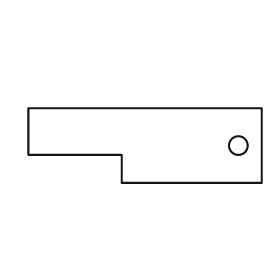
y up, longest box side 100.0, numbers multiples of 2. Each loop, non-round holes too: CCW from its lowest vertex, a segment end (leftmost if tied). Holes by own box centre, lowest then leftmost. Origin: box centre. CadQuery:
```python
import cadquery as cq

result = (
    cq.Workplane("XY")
    .moveTo(-10.0, -16.0)
    .lineTo(50.0, -16.0)
    .lineTo(50.0, 16.0)
    .lineTo(-50.0, 16.0)
    .lineTo(-50.0, -4.0)
    .lineTo(-10.0, -4.0)
    .close()
    .moveTo(40.0, 0.0)
    .circle(4.0)
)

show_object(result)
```